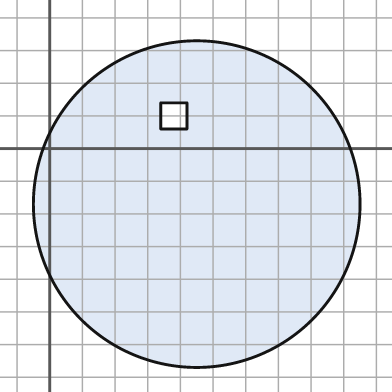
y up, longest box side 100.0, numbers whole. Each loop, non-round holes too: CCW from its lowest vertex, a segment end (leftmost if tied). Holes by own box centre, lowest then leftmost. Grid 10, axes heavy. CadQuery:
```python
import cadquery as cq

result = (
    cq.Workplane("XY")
    .moveTo(45.0, -17.0)
    .circle(50.0)
    .moveTo(34.0, 6.0)
    .lineTo(42.0, 6.0)
    .lineTo(42.0, 14.0)
    .lineTo(34.0, 14.0)
    .close()
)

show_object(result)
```